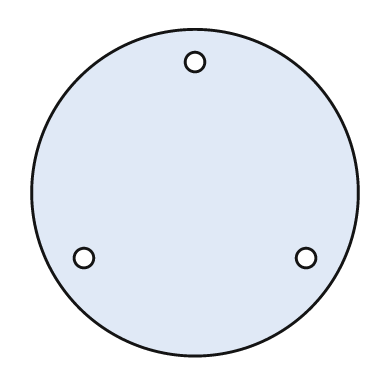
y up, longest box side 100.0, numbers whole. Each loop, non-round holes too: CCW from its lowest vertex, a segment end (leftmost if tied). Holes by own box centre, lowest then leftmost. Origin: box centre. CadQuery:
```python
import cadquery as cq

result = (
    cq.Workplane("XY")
    .moveTo(0.0, 0.0)
    .circle(50.0)
    .moveTo(-34.0, -20.0)
    .circle(3.0)
    .moveTo(34.0, -20.0)
    .circle(3.0)
    .moveTo(0.0, 40.0)
    .circle(3.0)
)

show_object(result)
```